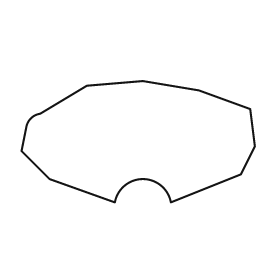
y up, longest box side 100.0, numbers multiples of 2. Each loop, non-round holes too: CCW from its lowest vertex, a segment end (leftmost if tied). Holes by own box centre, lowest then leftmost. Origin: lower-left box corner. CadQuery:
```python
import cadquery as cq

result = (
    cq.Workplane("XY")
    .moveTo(40.0, 0.0)
    .threePointArc((52.0, 10.0), (64.0, 0.0))
    .lineTo(94.0, 12.0)
    .lineTo(100.0, 24.0)
    .lineTo(98.0, 40.0)
    .lineTo(76.0, 48.0)
    .lineTo(52.0, 52.0)
    .lineTo(28.0, 50.0)
    .lineTo(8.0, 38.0)
    .threePointArc((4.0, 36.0), (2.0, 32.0))
    .lineTo(0.0, 22.0)
    .lineTo(12.0, 10.0)
    .close()
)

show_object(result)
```